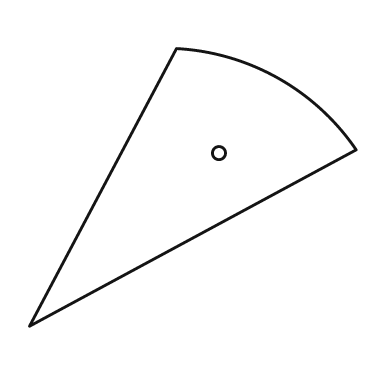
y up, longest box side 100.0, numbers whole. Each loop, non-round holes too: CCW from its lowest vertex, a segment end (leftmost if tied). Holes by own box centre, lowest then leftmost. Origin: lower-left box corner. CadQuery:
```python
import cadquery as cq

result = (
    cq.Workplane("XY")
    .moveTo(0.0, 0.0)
    .lineTo(100.0, 54.0)
    .threePointArc((76.0, 76.0), (45.0, 85.0))
    .close()
    .moveTo(58.0, 53.0)
    .circle(2.0)
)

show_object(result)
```